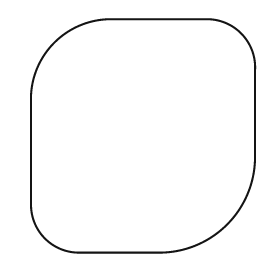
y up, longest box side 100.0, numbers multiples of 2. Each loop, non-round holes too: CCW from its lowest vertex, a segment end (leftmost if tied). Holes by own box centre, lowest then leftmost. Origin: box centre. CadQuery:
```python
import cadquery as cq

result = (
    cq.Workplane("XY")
    .moveTo(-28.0, -50.0)
    .lineTo(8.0, -50.0)
    .threePointArc((36.0, -38.0), (48.0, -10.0))
    .lineTo(48.0, 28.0)
    .threePointArc((42.0, 44.0), (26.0, 50.0))
    .lineTo(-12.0, 50.0)
    .threePointArc((-38.0, 40.0), (-48.0, 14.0))
    .lineTo(-48.0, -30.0)
    .threePointArc((-42.0, -44.0), (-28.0, -50.0))
    .close()
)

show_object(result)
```